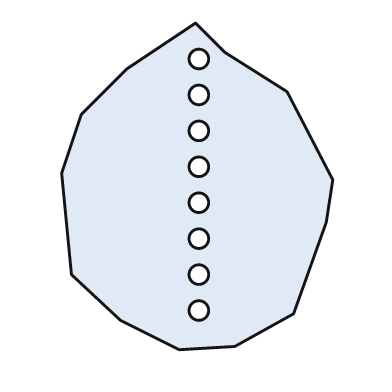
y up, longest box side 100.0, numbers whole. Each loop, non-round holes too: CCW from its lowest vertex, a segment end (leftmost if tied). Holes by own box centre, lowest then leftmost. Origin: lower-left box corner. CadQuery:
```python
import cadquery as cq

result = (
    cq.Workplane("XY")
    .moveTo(36.0, 0.0)
    .lineTo(53.0, 1.0)
    .lineTo(71.0, 11.0)
    .lineTo(81.0, 39.0)
    .lineTo(83.0, 52.0)
    .lineTo(69.0, 79.0)
    .lineTo(50.0, 91.0)
    .lineTo(41.0, 100.0)
    .lineTo(20.0, 86.0)
    .lineTo(6.0, 72.0)
    .lineTo(0.0, 54.0)
    .lineTo(3.0, 23.0)
    .lineTo(18.0, 9.0)
    .close()
    .moveTo(42.0, 12.0)
    .circle(3.0)
    .moveTo(42.0, 23.0)
    .circle(3.0)
    .moveTo(42.0, 34.0)
    .circle(3.0)
    .moveTo(42.0, 45.0)
    .circle(3.0)
    .moveTo(42.0, 56.0)
    .circle(3.0)
    .moveTo(42.0, 67.0)
    .circle(3.0)
    .moveTo(42.0, 78.0)
    .circle(3.0)
    .moveTo(42.0, 89.0)
    .circle(3.0)
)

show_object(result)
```